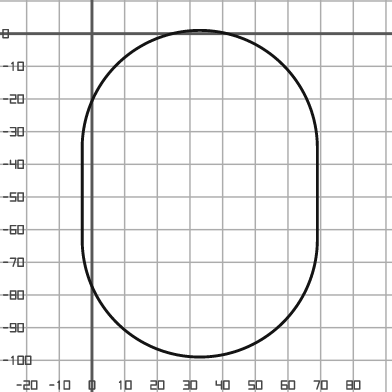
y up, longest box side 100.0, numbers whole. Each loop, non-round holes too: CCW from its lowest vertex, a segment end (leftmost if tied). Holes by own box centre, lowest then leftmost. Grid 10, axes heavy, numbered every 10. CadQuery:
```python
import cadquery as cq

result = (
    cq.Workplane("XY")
    .moveTo(-3.0, -63.0)
    .threePointArc((33.0, -99.0), (69.0, -63.0))
    .lineTo(69.0, -35.0)
    .threePointArc((33.0, 1.0), (-3.0, -35.0))
    .close()
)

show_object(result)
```